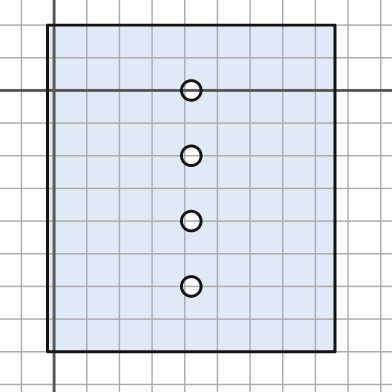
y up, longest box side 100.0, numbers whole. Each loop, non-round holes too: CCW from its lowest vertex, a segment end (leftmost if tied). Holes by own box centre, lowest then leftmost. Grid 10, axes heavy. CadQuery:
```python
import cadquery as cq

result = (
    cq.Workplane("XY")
    .moveTo(-2.0, -80.0)
    .lineTo(86.0, -80.0)
    .lineTo(86.0, 20.0)
    .lineTo(-2.0, 20.0)
    .close()
    .moveTo(42.0, -60.0)
    .circle(3.0)
    .moveTo(42.0, -40.0)
    .circle(3.0)
    .moveTo(42.0, -20.0)
    .circle(3.0)
    .moveTo(42.0, 0.0)
    .circle(3.0)
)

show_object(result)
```